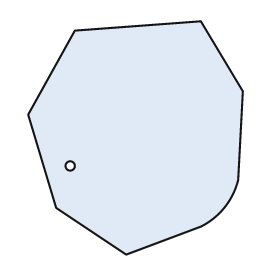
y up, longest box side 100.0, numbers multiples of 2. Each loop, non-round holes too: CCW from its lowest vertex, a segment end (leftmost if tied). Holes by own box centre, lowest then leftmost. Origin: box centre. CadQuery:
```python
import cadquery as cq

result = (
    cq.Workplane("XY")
    .moveTo(-4.0, -50.0)
    .lineTo(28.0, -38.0)
    .threePointArc((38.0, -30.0), (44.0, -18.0))
    .lineTo(46.0, 20.0)
    .lineTo(28.0, 50.0)
    .lineTo(-26.0, 46.0)
    .lineTo(-46.0, 10.0)
    .lineTo(-34.0, -30.0)
    .close()
    .moveTo(-28.0, -12.0)
    .circle(2.0)
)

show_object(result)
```